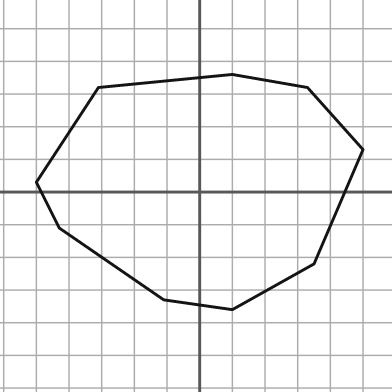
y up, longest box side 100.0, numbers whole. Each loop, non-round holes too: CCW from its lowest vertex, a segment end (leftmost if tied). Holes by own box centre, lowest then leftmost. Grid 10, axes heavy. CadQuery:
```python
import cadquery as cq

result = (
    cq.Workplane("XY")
    .moveTo(10.0, -36.0)
    .lineTo(35.0, -22.0)
    .lineTo(50.0, 13.0)
    .lineTo(33.0, 32.0)
    .lineTo(10.0, 36.0)
    .lineTo(-31.0, 32.0)
    .lineTo(-50.0, 3.0)
    .lineTo(-43.0, -11.0)
    .lineTo(-11.0, -33.0)
    .close()
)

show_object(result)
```